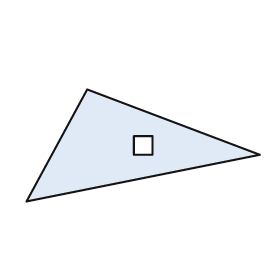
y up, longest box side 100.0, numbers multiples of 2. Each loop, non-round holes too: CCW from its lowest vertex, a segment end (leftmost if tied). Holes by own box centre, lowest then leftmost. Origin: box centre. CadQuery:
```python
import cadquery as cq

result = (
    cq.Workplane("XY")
    .moveTo(-50.0, -24.0)
    .lineTo(50.0, -4.0)
    .lineTo(-24.0, 24.0)
    .close()
    .moveTo(-4.0, -4.0)
    .lineTo(4.0, -4.0)
    .lineTo(4.0, 4.0)
    .lineTo(-4.0, 4.0)
    .close()
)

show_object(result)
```